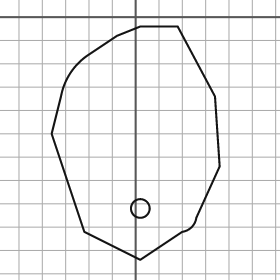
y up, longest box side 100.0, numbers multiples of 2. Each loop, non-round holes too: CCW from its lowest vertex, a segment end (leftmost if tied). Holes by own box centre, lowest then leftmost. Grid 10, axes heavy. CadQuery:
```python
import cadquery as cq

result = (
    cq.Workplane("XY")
    .moveTo(2.0, -104.0)
    .lineTo(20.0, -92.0)
    .threePointArc((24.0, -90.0), (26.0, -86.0))
    .lineTo(36.0, -64.0)
    .lineTo(34.0, -34.0)
    .lineTo(18.0, -4.0)
    .lineTo(2.0, -4.0)
    .lineTo(-8.0, -8.0)
    .lineTo(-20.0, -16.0)
    .threePointArc((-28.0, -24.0), (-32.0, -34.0))
    .lineTo(-36.0, -50.0)
    .lineTo(-22.0, -92.0)
    .close()
    .moveTo(2.0, -82.0)
    .circle(4.0)
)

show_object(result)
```